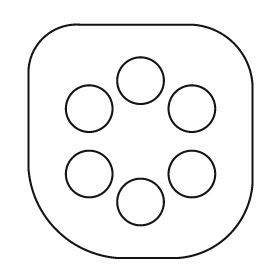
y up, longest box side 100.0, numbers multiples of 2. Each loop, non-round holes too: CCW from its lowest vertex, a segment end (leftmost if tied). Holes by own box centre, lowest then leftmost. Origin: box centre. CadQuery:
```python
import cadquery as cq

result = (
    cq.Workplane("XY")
    .moveTo(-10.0, -50.0)
    .lineTo(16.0, -50.0)
    .threePointArc((38.0, -40.0), (48.0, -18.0))
    .lineTo(48.0, 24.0)
    .threePointArc((40.0, 42.0), (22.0, 50.0))
    .lineTo(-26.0, 50.0)
    .threePointArc((-42.0, 44.0), (-48.0, 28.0))
    .lineTo(-48.0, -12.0)
    .threePointArc((-36.0, -38.0), (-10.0, -50.0))
    .close()
    .moveTo(0.0, -26.0)
    .circle(10.0)
    .moveTo(-22.0, -14.0)
    .circle(10.0)
    .moveTo(22.0, -14.0)
    .circle(10.0)
    .moveTo(-22.0, 14.0)
    .circle(10.0)
    .moveTo(22.0, 14.0)
    .circle(10.0)
    .moveTo(0.0, 26.0)
    .circle(10.0)
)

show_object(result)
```